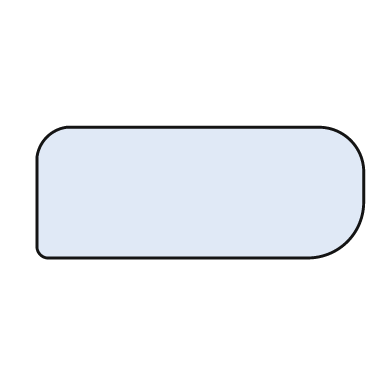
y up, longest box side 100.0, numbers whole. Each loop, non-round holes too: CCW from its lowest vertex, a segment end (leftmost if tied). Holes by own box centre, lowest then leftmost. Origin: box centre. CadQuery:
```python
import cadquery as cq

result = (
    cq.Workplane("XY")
    .moveTo(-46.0, -20.0)
    .lineTo(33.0, -20.0)
    .threePointArc((45.0, -15.0), (50.0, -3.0))
    .lineTo(50.0, 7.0)
    .threePointArc((46.0, 16.0), (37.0, 20.0))
    .lineTo(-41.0, 20.0)
    .threePointArc((-47.0, 17.0), (-50.0, 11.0))
    .lineTo(-50.0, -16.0)
    .threePointArc((-49.0, -19.0), (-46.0, -20.0))
    .close()
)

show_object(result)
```